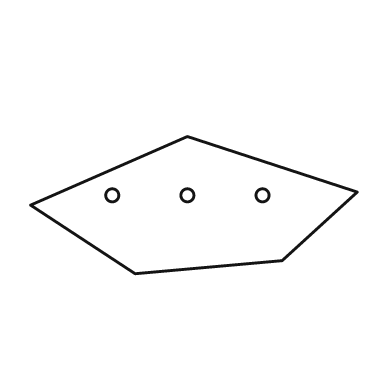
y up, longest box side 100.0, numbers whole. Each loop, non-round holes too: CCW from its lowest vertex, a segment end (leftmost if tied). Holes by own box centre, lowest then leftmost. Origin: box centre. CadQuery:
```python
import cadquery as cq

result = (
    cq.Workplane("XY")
    .moveTo(-18.0, -21.0)
    .lineTo(27.0, -17.0)
    .lineTo(50.0, 4.0)
    .lineTo(-2.0, 21.0)
    .lineTo(-50.0, 0.0)
    .close()
    .moveTo(-25.0, 3.0)
    .circle(2.0)
    .moveTo(-2.0, 3.0)
    .circle(2.0)
    .moveTo(21.0, 3.0)
    .circle(2.0)
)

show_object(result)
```